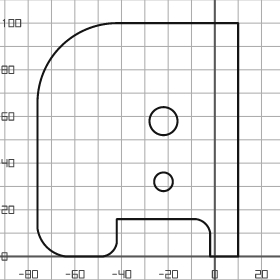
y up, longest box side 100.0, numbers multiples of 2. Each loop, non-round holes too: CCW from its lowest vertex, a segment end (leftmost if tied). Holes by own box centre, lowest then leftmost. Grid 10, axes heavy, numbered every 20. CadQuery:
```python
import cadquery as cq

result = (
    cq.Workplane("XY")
    .moveTo(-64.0, 0.0)
    .lineTo(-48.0, 0.0)
    .threePointArc((-44.0, 2.0), (-42.0, 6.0))
    .lineTo(-42.0, 16.0)
    .lineTo(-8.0, 16.0)
    .threePointArc((-4.0, 14.0), (-2.0, 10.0))
    .lineTo(-2.0, 0.0)
    .lineTo(10.0, 0.0)
    .lineTo(10.0, 100.0)
    .lineTo(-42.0, 100.0)
    .threePointArc((-66.0, 90.0), (-76.0, 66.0))
    .lineTo(-76.0, 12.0)
    .threePointArc((-72.0, 4.0), (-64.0, 0.0))
    .close()
    .moveTo(-22.0, 32.0)
    .circle(4.0)
    .moveTo(-22.0, 58.0)
    .circle(6.0)
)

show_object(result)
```